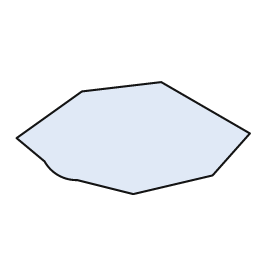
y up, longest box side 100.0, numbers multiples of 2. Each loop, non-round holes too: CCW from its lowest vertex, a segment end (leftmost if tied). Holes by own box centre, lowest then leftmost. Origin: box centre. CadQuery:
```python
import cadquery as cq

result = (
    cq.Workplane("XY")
    .moveTo(0.0, -24.0)
    .lineTo(34.0, -16.0)
    .lineTo(50.0, 2.0)
    .lineTo(12.0, 24.0)
    .lineTo(-22.0, 20.0)
    .lineTo(-50.0, 0.0)
    .lineTo(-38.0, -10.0)
    .threePointArc((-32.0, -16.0), (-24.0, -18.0))
    .close()
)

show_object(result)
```